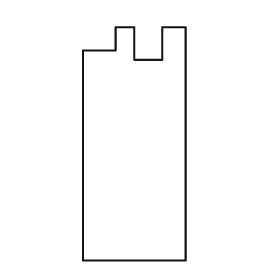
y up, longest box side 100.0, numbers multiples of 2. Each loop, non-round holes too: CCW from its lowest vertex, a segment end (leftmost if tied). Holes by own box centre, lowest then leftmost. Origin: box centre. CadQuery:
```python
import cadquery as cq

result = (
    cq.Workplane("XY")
    .moveTo(-22.0, -50.0)
    .lineTo(22.0, -50.0)
    .lineTo(22.0, 50.0)
    .lineTo(12.0, 50.0)
    .lineTo(12.0, 36.0)
    .lineTo(0.0, 36.0)
    .lineTo(0.0, 50.0)
    .lineTo(-8.0, 50.0)
    .lineTo(-8.0, 40.0)
    .lineTo(-22.0, 40.0)
    .close()
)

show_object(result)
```